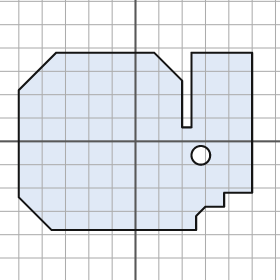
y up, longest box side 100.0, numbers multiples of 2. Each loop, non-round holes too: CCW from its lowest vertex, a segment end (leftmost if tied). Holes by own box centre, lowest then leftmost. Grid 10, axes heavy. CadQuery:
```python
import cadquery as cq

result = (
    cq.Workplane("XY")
    .moveTo(-36.0, -38.0)
    .lineTo(26.0, -38.0)
    .lineTo(26.0, -32.0)
    .lineTo(30.0, -28.0)
    .lineTo(38.0, -28.0)
    .lineTo(38.0, -22.0)
    .lineTo(50.0, -22.0)
    .lineTo(50.0, 38.0)
    .lineTo(24.0, 38.0)
    .lineTo(24.0, 6.0)
    .lineTo(20.0, 6.0)
    .lineTo(20.0, 26.0)
    .lineTo(8.0, 38.0)
    .lineTo(-34.0, 38.0)
    .lineTo(-50.0, 22.0)
    .lineTo(-50.0, -24.0)
    .close()
    .moveTo(28.0, -6.0)
    .circle(4.0)
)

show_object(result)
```